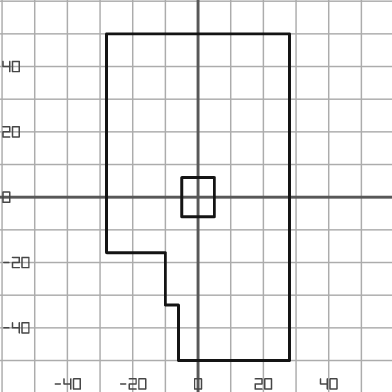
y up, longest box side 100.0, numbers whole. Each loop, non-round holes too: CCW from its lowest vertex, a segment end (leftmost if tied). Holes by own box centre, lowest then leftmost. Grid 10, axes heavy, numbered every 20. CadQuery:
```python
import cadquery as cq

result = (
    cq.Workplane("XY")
    .moveTo(-6.0, -50.0)
    .lineTo(28.0, -50.0)
    .lineTo(28.0, 50.0)
    .lineTo(-28.0, 50.0)
    .lineTo(-28.0, -17.0)
    .lineTo(-10.0, -17.0)
    .lineTo(-10.0, -33.0)
    .lineTo(-6.0, -33.0)
    .close()
    .moveTo(-5.0, -6.0)
    .lineTo(5.0, -6.0)
    .lineTo(5.0, 6.0)
    .lineTo(-5.0, 6.0)
    .close()
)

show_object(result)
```